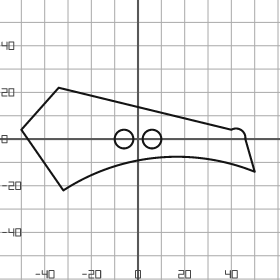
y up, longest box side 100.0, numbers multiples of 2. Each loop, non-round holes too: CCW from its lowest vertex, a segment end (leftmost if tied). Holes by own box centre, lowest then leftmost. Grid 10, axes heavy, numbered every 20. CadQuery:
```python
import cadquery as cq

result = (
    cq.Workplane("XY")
    .moveTo(-32.0, -22.0)
    .threePointArc((8.0, -8.0), (50.0, -14.0))
    .lineTo(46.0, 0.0)
    .threePointArc((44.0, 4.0), (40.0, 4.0))
    .lineTo(-34.0, 22.0)
    .lineTo(-50.0, 4.0)
    .close()
    .moveTo(-6.0, 0.0)
    .circle(4.0)
    .moveTo(6.0, 0.0)
    .circle(4.0)
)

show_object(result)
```